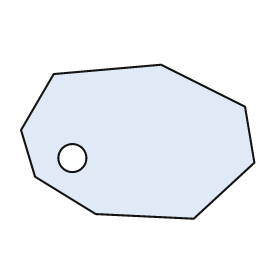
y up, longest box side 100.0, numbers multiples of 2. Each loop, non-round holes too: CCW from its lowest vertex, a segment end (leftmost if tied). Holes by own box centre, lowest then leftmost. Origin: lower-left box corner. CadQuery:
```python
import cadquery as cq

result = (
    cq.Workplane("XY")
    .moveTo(74.0, 0.0)
    .lineTo(100.0, 24.0)
    .lineTo(96.0, 48.0)
    .lineTo(60.0, 66.0)
    .lineTo(14.0, 62.0)
    .lineTo(0.0, 38.0)
    .lineTo(6.0, 18.0)
    .lineTo(32.0, 2.0)
    .close()
    .moveTo(22.0, 26.0)
    .circle(6.0)
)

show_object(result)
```